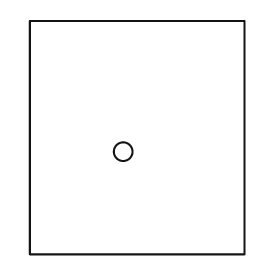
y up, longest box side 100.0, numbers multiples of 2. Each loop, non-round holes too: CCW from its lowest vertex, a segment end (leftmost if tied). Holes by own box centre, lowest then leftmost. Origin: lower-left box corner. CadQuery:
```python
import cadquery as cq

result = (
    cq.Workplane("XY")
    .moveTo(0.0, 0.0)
    .lineTo(92.0, 0.0)
    .lineTo(92.0, 100.0)
    .lineTo(0.0, 100.0)
    .close()
    .moveTo(40.0, 44.0)
    .circle(4.0)
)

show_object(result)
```